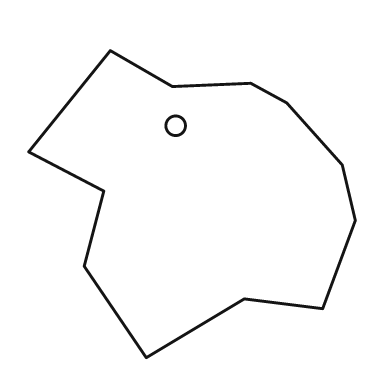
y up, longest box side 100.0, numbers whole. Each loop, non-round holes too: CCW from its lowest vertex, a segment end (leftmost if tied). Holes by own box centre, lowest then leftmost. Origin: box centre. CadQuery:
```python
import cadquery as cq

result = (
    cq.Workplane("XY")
    .moveTo(-14.0, -47.0)
    .lineTo(16.0, -29.0)
    .lineTo(40.0, -32.0)
    .lineTo(50.0, -5.0)
    .lineTo(46.0, 12.0)
    .lineTo(29.0, 31.0)
    .lineTo(18.0, 37.0)
    .lineTo(-6.0, 36.0)
    .lineTo(-25.0, 47.0)
    .lineTo(-50.0, 16.0)
    .lineTo(-27.0, 4.0)
    .lineTo(-33.0, -19.0)
    .close()
    .moveTo(-5.0, 24.0)
    .circle(3.0)
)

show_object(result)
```